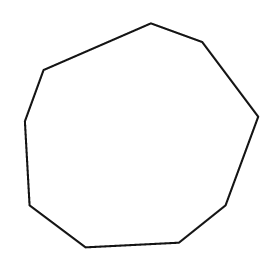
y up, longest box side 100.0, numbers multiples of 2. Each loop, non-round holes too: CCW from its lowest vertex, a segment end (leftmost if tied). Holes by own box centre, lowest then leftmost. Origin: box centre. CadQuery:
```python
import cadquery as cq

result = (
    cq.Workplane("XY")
    .moveTo(-24.0, -48.0)
    .lineTo(16.0, -46.0)
    .lineTo(36.0, -30.0)
    .lineTo(50.0, 8.0)
    .lineTo(26.0, 40.0)
    .lineTo(4.0, 48.0)
    .lineTo(-42.0, 28.0)
    .lineTo(-50.0, 6.0)
    .lineTo(-48.0, -30.0)
    .close()
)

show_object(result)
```